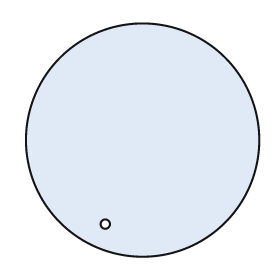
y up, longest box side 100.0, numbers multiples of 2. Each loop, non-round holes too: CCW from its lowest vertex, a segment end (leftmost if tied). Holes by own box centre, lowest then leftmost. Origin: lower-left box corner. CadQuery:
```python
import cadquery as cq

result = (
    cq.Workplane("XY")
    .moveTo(50.0, 50.0)
    .circle(50.0)
    .moveTo(34.0, 14.0)
    .circle(2.0)
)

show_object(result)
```